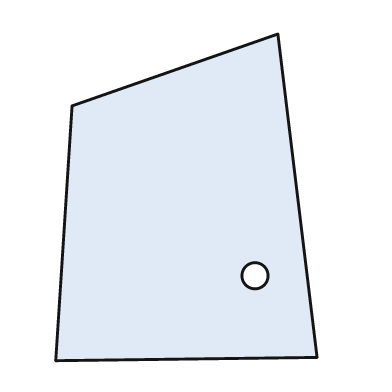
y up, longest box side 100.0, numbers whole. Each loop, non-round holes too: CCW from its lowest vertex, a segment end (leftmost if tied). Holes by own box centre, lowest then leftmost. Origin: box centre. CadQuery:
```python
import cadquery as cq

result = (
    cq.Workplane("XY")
    .moveTo(-40.0, -50.0)
    .lineTo(40.0, -49.0)
    .lineTo(28.0, 50.0)
    .lineTo(-35.0, 28.0)
    .close()
    .moveTo(21.0, -24.0)
    .circle(4.0)
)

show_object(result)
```